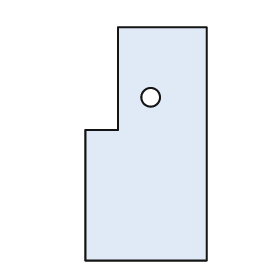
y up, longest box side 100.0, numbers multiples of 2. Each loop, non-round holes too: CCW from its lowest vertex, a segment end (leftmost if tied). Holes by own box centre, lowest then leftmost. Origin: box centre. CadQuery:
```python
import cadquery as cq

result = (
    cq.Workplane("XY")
    .moveTo(-26.0, -50.0)
    .lineTo(26.0, -50.0)
    .lineTo(26.0, 50.0)
    .lineTo(-12.0, 50.0)
    .lineTo(-12.0, 6.0)
    .lineTo(-26.0, 6.0)
    .close()
    .moveTo(2.0, 20.0)
    .circle(4.0)
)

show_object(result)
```